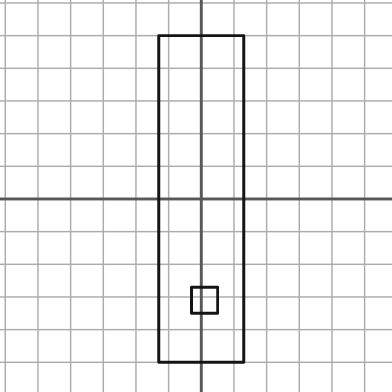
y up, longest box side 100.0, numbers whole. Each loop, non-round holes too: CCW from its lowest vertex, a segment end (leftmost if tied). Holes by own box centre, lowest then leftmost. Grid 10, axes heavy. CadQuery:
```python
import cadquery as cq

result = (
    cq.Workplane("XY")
    .moveTo(-13.0, -50.0)
    .lineTo(13.0, -50.0)
    .lineTo(13.0, 50.0)
    .lineTo(-13.0, 50.0)
    .close()
    .moveTo(-3.0, -35.0)
    .lineTo(5.0, -35.0)
    .lineTo(5.0, -27.0)
    .lineTo(-3.0, -27.0)
    .close()
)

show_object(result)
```